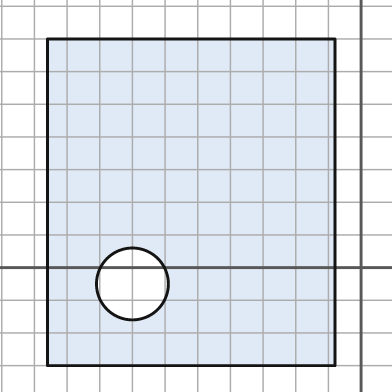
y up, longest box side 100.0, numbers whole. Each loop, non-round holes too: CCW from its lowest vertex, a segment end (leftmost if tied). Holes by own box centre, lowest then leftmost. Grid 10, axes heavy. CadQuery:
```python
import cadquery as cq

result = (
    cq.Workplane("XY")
    .moveTo(-96.0, -30.0)
    .lineTo(-8.0, -30.0)
    .lineTo(-8.0, 70.0)
    .lineTo(-96.0, 70.0)
    .close()
    .moveTo(-70.0, -5.0)
    .circle(11.0)
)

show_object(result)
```